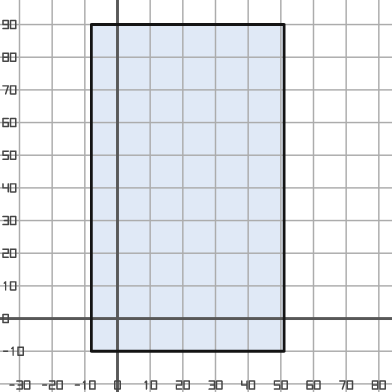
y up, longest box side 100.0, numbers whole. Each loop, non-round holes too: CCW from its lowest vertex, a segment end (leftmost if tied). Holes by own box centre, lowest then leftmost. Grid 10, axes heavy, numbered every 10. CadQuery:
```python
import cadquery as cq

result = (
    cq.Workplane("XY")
    .moveTo(-8.0, -10.0)
    .lineTo(51.0, -10.0)
    .lineTo(51.0, 90.0)
    .lineTo(-8.0, 90.0)
    .close()
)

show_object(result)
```